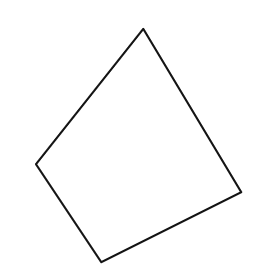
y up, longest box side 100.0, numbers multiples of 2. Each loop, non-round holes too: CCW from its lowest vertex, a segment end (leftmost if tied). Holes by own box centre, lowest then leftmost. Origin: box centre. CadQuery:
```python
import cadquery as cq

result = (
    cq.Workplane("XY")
    .moveTo(-16.0, -50.0)
    .lineTo(44.0, -20.0)
    .lineTo(2.0, 50.0)
    .lineTo(-44.0, -8.0)
    .close()
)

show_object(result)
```